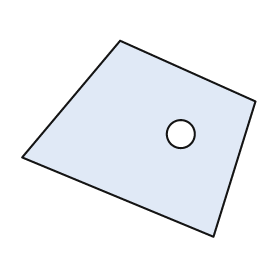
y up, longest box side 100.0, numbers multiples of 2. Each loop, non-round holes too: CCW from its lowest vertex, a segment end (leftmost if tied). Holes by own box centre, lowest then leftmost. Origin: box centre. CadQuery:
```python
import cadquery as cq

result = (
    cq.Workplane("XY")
    .moveTo(32.0, -42.0)
    .lineTo(50.0, 16.0)
    .lineTo(-8.0, 42.0)
    .lineTo(-50.0, -8.0)
    .close()
    .moveTo(18.0, 2.0)
    .circle(6.0)
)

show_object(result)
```